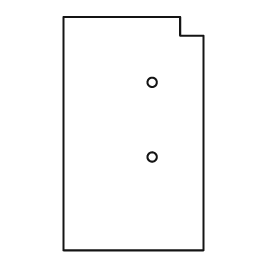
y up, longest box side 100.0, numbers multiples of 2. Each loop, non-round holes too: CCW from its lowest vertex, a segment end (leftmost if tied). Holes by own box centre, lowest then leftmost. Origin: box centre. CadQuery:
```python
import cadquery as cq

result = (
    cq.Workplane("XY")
    .moveTo(-30.0, -50.0)
    .lineTo(30.0, -50.0)
    .lineTo(30.0, 42.0)
    .lineTo(20.0, 42.0)
    .lineTo(20.0, 50.0)
    .lineTo(-30.0, 50.0)
    .close()
    .moveTo(8.0, -10.0)
    .circle(2.0)
    .moveTo(8.0, 22.0)
    .circle(2.0)
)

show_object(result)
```